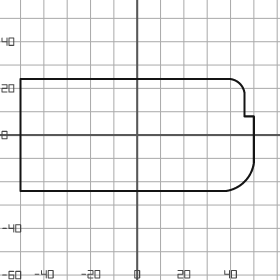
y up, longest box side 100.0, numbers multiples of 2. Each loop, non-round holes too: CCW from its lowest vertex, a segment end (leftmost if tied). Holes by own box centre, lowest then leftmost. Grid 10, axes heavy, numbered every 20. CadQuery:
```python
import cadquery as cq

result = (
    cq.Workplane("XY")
    .moveTo(-50.0, -24.0)
    .lineTo(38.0, -24.0)
    .threePointArc((46.0, -20.0), (50.0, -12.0))
    .lineTo(50.0, 8.0)
    .lineTo(46.0, 8.0)
    .lineTo(46.0, 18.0)
    .threePointArc((44.0, 22.0), (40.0, 24.0))
    .lineTo(-50.0, 24.0)
    .close()
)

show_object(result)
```